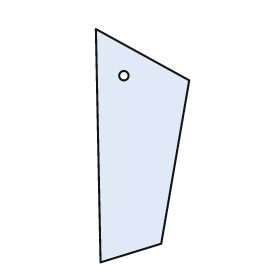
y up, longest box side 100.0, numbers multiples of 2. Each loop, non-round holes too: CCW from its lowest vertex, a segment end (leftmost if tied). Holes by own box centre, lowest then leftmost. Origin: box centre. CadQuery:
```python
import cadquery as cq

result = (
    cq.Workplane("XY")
    .moveTo(-18.0, -50.0)
    .lineTo(8.0, -42.0)
    .lineTo(20.0, 28.0)
    .lineTo(-20.0, 50.0)
    .close()
    .moveTo(-8.0, 30.0)
    .circle(2.0)
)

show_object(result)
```